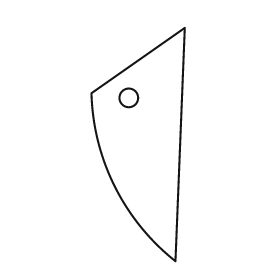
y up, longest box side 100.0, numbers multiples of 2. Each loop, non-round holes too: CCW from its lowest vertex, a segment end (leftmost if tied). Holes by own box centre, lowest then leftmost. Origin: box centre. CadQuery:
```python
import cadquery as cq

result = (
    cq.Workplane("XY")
    .moveTo(16.0, -50.0)
    .lineTo(20.0, 50.0)
    .lineTo(-20.0, 22.0)
    .threePointArc((-10.0, -18.0), (16.0, -50.0))
    .close()
    .moveTo(-4.0, 20.0)
    .circle(4.0)
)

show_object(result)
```